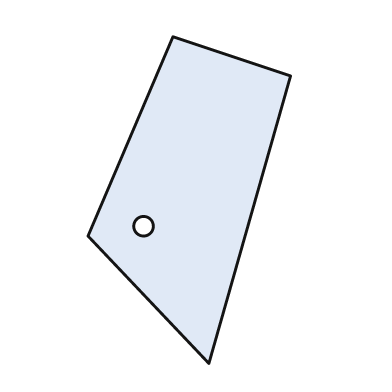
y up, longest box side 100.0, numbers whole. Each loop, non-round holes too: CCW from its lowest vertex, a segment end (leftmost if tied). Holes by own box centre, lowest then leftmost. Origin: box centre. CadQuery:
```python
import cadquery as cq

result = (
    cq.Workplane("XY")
    .moveTo(6.0, -50.0)
    .lineTo(31.0, 38.0)
    .lineTo(-5.0, 50.0)
    .lineTo(-31.0, -11.0)
    .close()
    .moveTo(-14.0, -8.0)
    .circle(3.0)
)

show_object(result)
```